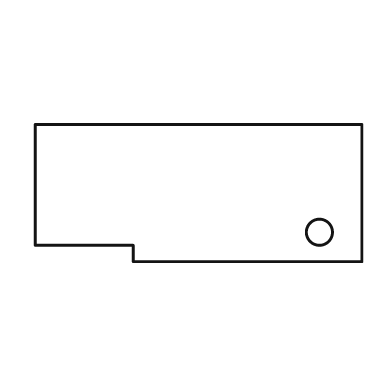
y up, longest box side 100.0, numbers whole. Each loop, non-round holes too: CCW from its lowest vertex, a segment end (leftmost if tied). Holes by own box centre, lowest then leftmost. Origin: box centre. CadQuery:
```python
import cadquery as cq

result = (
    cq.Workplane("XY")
    .moveTo(-20.0, -21.0)
    .lineTo(50.0, -21.0)
    .lineTo(50.0, 21.0)
    .lineTo(-50.0, 21.0)
    .lineTo(-50.0, -16.0)
    .lineTo(-20.0, -16.0)
    .close()
    .moveTo(37.0, -12.0)
    .circle(4.0)
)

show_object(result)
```